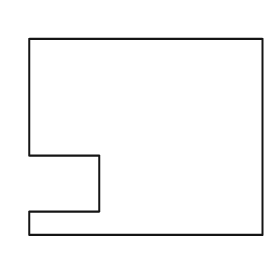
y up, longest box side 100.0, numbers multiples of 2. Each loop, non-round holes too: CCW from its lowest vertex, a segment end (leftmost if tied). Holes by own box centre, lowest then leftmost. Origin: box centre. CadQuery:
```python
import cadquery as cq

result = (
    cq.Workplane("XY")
    .moveTo(-50.0, -42.0)
    .lineTo(50.0, -42.0)
    .lineTo(50.0, 42.0)
    .lineTo(-50.0, 42.0)
    .lineTo(-50.0, -8.0)
    .lineTo(-20.0, -8.0)
    .lineTo(-20.0, -32.0)
    .lineTo(-50.0, -32.0)
    .close()
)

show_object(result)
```